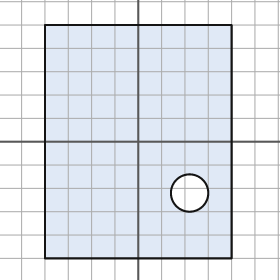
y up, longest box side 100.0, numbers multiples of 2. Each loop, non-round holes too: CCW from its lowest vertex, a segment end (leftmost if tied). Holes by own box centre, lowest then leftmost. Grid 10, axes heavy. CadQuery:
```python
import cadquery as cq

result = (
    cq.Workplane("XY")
    .moveTo(-40.0, -50.0)
    .lineTo(40.0, -50.0)
    .lineTo(40.0, 50.0)
    .lineTo(-40.0, 50.0)
    .close()
    .moveTo(22.0, -22.0)
    .circle(8.0)
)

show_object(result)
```